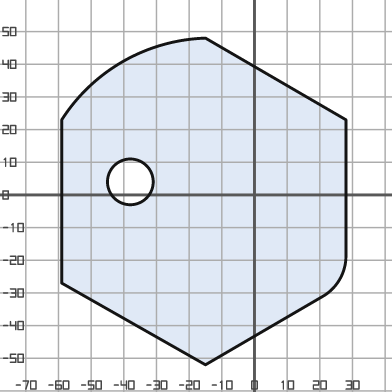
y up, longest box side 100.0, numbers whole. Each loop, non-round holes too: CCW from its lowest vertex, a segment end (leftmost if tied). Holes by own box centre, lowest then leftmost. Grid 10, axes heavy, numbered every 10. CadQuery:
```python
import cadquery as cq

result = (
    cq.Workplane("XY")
    .moveTo(-15.0, -52.0)
    .lineTo(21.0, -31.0)
    .threePointArc((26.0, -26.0), (28.0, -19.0))
    .lineTo(28.0, 23.0)
    .lineTo(-15.0, 48.0)
    .threePointArc((-40.0, 41.0), (-59.0, 23.0))
    .lineTo(-59.0, -27.0)
    .close()
    .moveTo(-38.0, 4.0)
    .circle(7.0)
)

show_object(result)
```